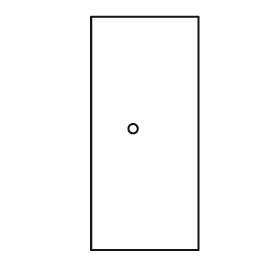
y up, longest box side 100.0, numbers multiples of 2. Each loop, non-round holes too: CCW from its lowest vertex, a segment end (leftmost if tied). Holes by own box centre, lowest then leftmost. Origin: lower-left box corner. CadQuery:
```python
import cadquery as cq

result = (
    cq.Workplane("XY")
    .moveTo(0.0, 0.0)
    .lineTo(46.0, 0.0)
    .lineTo(46.0, 100.0)
    .lineTo(0.0, 100.0)
    .close()
    .moveTo(18.0, 52.0)
    .circle(2.0)
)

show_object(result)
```